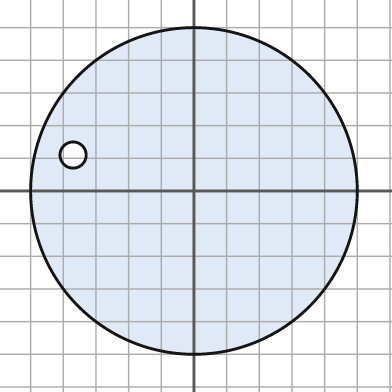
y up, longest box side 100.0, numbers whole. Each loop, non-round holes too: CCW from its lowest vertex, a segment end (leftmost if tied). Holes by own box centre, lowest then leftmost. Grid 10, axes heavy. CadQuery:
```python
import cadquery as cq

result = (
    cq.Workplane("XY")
    .moveTo(0.0, 0.0)
    .circle(50.0)
    .moveTo(-37.0, 11.0)
    .circle(4.0)
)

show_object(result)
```